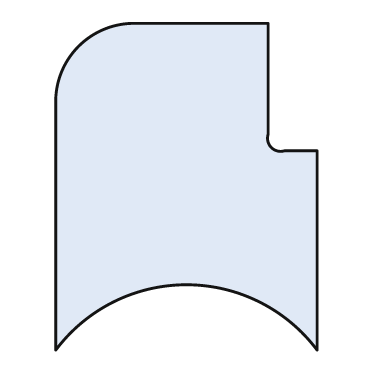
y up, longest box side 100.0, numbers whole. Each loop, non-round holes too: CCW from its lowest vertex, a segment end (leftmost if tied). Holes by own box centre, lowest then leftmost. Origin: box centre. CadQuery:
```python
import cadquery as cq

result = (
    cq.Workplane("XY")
    .moveTo(-40.0, -50.0)
    .threePointArc((0.0, -30.0), (40.0, -50.0))
    .lineTo(40.0, 11.0)
    .lineTo(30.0, 11.0)
    .threePointArc((26.0, 12.0), (25.0, 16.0))
    .lineTo(25.0, 50.0)
    .lineTo(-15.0, 50.0)
    .threePointArc((-33.0, 43.0), (-40.0, 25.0))
    .close()
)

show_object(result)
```